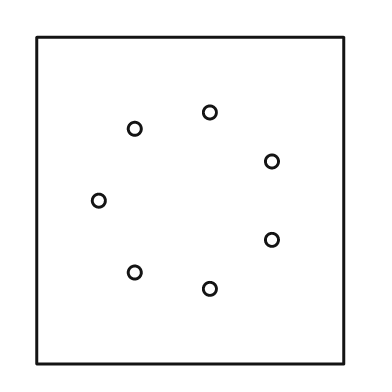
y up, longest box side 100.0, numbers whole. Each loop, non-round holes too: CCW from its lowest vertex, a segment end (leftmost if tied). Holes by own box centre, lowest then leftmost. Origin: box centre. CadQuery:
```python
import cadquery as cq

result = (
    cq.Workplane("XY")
    .moveTo(-47.0, -50.0)
    .lineTo(47.0, -50.0)
    .lineTo(47.0, 50.0)
    .lineTo(-47.0, 50.0)
    .close()
    .moveTo(6.0, -27.0)
    .circle(2.0)
    .moveTo(-17.0, -22.0)
    .circle(2.0)
    .moveTo(25.0, -12.0)
    .circle(2.0)
    .moveTo(-28.0, 0.0)
    .circle(2.0)
    .moveTo(25.0, 12.0)
    .circle(2.0)
    .moveTo(-17.0, 22.0)
    .circle(2.0)
    .moveTo(6.0, 27.0)
    .circle(2.0)
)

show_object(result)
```